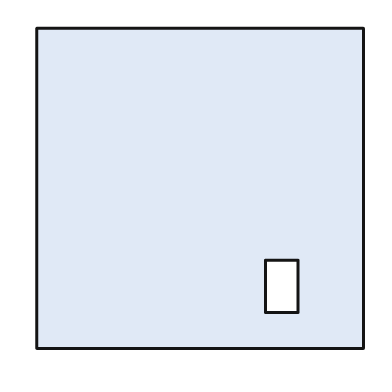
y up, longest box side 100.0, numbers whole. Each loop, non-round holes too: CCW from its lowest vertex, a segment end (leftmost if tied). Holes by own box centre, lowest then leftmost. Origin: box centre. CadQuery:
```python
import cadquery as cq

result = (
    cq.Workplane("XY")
    .moveTo(-50.0, -49.0)
    .lineTo(50.0, -49.0)
    .lineTo(50.0, 49.0)
    .lineTo(-50.0, 49.0)
    .close()
    .moveTo(20.0, -38.0)
    .lineTo(30.0, -38.0)
    .lineTo(30.0, -22.0)
    .lineTo(20.0, -22.0)
    .close()
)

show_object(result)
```